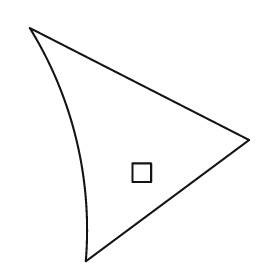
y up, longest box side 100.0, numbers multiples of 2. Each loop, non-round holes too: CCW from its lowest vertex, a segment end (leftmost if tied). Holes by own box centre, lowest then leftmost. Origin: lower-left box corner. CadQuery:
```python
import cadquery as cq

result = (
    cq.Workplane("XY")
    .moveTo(24.0, 0.0)
    .lineTo(94.0, 52.0)
    .lineTo(0.0, 100.0)
    .threePointArc((20.0, 52.0), (24.0, 0.0))
    .close()
    .moveTo(44.0, 34.0)
    .lineTo(52.0, 34.0)
    .lineTo(52.0, 42.0)
    .lineTo(44.0, 42.0)
    .close()
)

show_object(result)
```